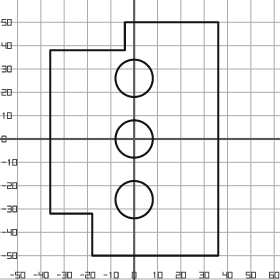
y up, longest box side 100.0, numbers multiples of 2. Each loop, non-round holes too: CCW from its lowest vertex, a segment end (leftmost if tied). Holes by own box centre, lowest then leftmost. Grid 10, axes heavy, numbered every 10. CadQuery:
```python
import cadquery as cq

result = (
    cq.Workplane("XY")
    .moveTo(-18.0, -50.0)
    .lineTo(36.0, -50.0)
    .lineTo(36.0, 50.0)
    .lineTo(-4.0, 50.0)
    .lineTo(-4.0, 38.0)
    .lineTo(-36.0, 38.0)
    .lineTo(-36.0, -32.0)
    .lineTo(-18.0, -32.0)
    .close()
    .moveTo(0.0, -26.0)
    .circle(8.0)
    .moveTo(0.0, 0.0)
    .circle(8.0)
    .moveTo(0.0, 26.0)
    .circle(8.0)
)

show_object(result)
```